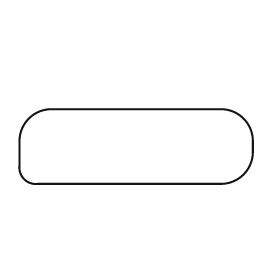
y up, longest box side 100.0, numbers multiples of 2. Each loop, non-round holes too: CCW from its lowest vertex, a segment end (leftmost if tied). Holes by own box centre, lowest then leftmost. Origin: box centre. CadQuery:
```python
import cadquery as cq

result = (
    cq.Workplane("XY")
    .moveTo(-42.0, -16.0)
    .lineTo(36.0, -16.0)
    .threePointArc((46.0, -12.0), (50.0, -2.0))
    .lineTo(50.0, 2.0)
    .threePointArc((46.0, 12.0), (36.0, 16.0))
    .lineTo(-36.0, 16.0)
    .threePointArc((-46.0, 12.0), (-50.0, 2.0))
    .lineTo(-50.0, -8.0)
    .threePointArc((-48.0, -14.0), (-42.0, -16.0))
    .close()
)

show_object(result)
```